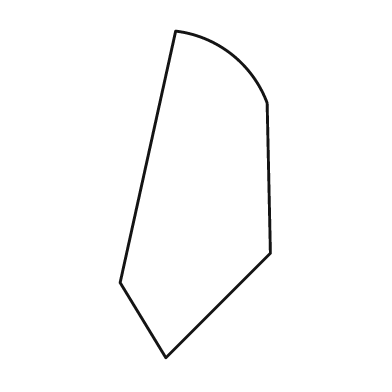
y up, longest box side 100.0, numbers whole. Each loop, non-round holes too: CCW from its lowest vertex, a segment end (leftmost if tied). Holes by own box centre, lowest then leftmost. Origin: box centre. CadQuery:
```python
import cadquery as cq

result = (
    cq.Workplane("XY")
    .moveTo(-9.0, -50.0)
    .lineTo(23.0, -18.0)
    .lineTo(22.0, 28.0)
    .threePointArc((11.0, 43.0), (-6.0, 50.0))
    .lineTo(-23.0, -27.0)
    .close()
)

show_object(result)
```